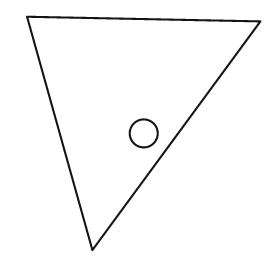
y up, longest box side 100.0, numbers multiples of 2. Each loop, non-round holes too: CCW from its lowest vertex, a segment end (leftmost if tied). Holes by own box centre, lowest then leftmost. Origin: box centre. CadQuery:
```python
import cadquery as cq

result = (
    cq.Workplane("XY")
    .moveTo(-22.0, -50.0)
    .lineTo(50.0, 48.0)
    .lineTo(-50.0, 50.0)
    .close()
    .moveTo(0.0, 0.0)
    .circle(6.0)
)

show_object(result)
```